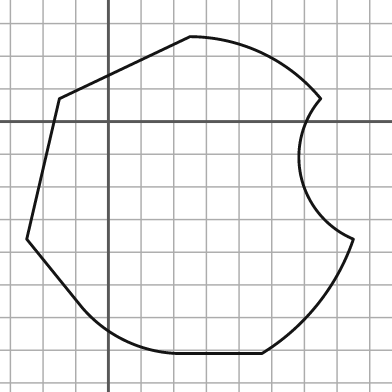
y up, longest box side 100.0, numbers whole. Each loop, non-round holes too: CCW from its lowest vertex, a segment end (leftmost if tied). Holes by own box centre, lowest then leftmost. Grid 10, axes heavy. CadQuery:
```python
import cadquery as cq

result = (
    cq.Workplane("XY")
    .moveTo(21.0, -71.0)
    .lineTo(47.0, -71.0)
    .threePointArc((64.0, -56.0), (75.0, -36.0))
    .threePointArc((59.0, -17.0), (65.0, 7.0))
    .threePointArc((47.0, 21.0), (25.0, 26.0))
    .lineTo(-15.0, 7.0)
    .lineTo(-25.0, -36.0)
    .lineTo(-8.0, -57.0)
    .threePointArc((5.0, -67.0), (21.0, -71.0))
    .close()
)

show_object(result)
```